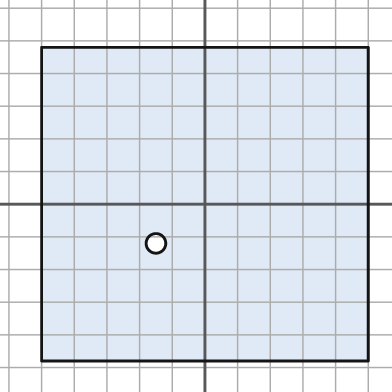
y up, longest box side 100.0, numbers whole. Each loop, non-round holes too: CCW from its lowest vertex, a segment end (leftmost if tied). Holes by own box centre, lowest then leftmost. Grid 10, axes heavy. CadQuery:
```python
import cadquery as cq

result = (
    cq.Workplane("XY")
    .moveTo(-50.0, -48.0)
    .lineTo(50.0, -48.0)
    .lineTo(50.0, 48.0)
    .lineTo(-50.0, 48.0)
    .close()
    .moveTo(-15.0, -12.0)
    .circle(3.0)
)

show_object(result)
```